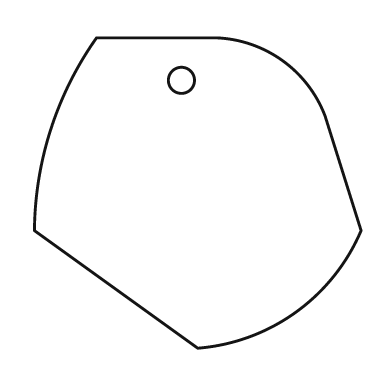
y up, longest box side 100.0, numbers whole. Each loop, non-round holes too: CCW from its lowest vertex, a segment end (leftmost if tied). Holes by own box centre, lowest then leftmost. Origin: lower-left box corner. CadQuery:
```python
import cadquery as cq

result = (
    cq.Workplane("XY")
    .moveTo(50.0, 0.0)
    .threePointArc((80.0, 11.0), (100.0, 36.0))
    .lineTo(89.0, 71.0)
    .threePointArc((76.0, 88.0), (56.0, 95.0))
    .lineTo(19.0, 95.0)
    .threePointArc((5.0, 67.0), (0.0, 36.0))
    .close()
    .moveTo(45.0, 82.0)
    .circle(4.0)
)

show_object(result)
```